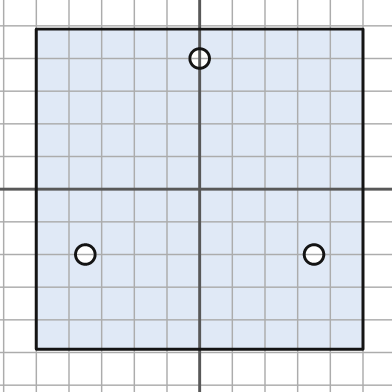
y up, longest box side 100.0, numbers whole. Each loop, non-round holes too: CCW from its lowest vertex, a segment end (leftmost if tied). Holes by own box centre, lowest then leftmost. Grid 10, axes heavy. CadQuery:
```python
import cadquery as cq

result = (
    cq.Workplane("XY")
    .moveTo(-50.0, -49.0)
    .lineTo(50.0, -49.0)
    .lineTo(50.0, 49.0)
    .lineTo(-50.0, 49.0)
    .close()
    .moveTo(-35.0, -20.0)
    .circle(3.0)
    .moveTo(35.0, -20.0)
    .circle(3.0)
    .moveTo(0.0, 40.0)
    .circle(3.0)
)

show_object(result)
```